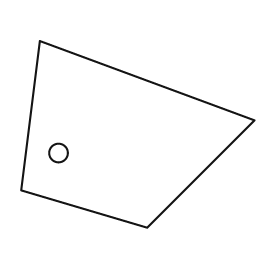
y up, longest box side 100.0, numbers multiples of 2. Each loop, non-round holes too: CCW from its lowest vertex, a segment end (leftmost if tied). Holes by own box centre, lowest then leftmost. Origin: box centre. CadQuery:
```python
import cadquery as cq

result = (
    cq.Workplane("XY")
    .moveTo(4.0, -40.0)
    .lineTo(50.0, 6.0)
    .lineTo(-42.0, 40.0)
    .lineTo(-50.0, -24.0)
    .close()
    .moveTo(-34.0, -8.0)
    .circle(4.0)
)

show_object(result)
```